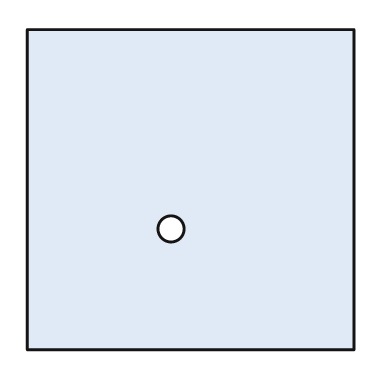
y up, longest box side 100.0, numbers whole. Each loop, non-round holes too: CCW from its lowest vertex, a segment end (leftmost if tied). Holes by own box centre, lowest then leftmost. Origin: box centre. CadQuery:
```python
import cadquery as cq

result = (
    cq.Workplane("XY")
    .moveTo(-50.0, -49.0)
    .lineTo(50.0, -49.0)
    .lineTo(50.0, 49.0)
    .lineTo(-50.0, 49.0)
    .close()
    .moveTo(-6.0, -12.0)
    .circle(4.0)
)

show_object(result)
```